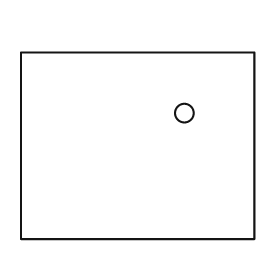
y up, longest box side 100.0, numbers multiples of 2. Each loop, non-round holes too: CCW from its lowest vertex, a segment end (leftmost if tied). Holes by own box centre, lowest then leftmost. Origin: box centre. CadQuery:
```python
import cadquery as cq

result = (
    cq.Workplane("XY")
    .moveTo(-50.0, -40.0)
    .lineTo(50.0, -40.0)
    .lineTo(50.0, 40.0)
    .lineTo(-50.0, 40.0)
    .close()
    .moveTo(20.0, 14.0)
    .circle(4.0)
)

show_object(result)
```